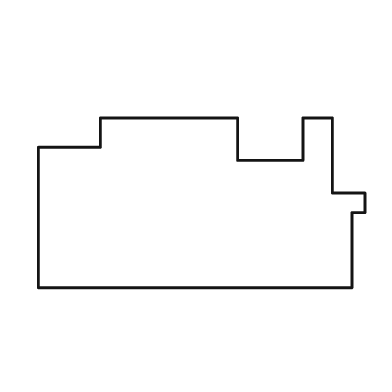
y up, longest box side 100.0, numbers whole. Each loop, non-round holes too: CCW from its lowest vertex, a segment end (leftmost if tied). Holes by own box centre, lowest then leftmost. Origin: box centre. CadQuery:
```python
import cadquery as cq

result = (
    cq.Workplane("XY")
    .moveTo(-50.0, -26.0)
    .lineTo(46.0, -26.0)
    .lineTo(46.0, -3.0)
    .lineTo(50.0, -3.0)
    .lineTo(50.0, 3.0)
    .lineTo(40.0, 3.0)
    .lineTo(40.0, 26.0)
    .lineTo(31.0, 26.0)
    .lineTo(31.0, 13.0)
    .lineTo(11.0, 13.0)
    .lineTo(11.0, 26.0)
    .lineTo(-31.0, 26.0)
    .lineTo(-31.0, 17.0)
    .lineTo(-50.0, 17.0)
    .close()
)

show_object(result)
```